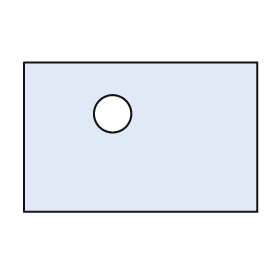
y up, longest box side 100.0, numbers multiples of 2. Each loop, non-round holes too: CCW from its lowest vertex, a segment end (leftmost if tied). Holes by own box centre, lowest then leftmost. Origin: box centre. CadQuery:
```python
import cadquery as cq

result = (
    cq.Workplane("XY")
    .moveTo(-50.0, -32.0)
    .lineTo(50.0, -32.0)
    .lineTo(50.0, 32.0)
    .lineTo(-50.0, 32.0)
    .close()
    .moveTo(-12.0, 10.0)
    .circle(8.0)
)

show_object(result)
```